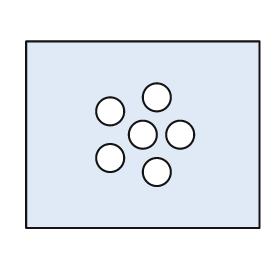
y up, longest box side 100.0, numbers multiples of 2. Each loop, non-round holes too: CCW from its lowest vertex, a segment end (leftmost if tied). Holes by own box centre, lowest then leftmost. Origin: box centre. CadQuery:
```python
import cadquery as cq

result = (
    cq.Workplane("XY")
    .moveTo(-50.0, -40.0)
    .lineTo(50.0, -40.0)
    .lineTo(50.0, 40.0)
    .lineTo(-50.0, 40.0)
    .close()
    .moveTo(6.0, -16.0)
    .circle(6.0)
    .moveTo(-14.0, -10.0)
    .circle(6.0)
    .moveTo(0.0, 0.0)
    .circle(6.0)
    .moveTo(16.0, 0.0)
    .circle(6.0)
    .moveTo(-14.0, 10.0)
    .circle(6.0)
    .moveTo(6.0, 16.0)
    .circle(6.0)
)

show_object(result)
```